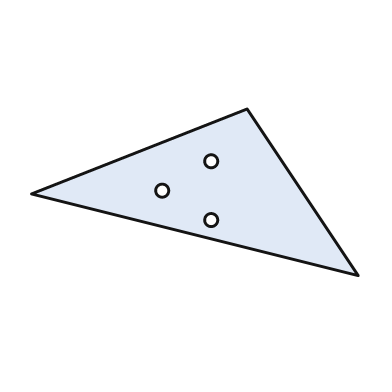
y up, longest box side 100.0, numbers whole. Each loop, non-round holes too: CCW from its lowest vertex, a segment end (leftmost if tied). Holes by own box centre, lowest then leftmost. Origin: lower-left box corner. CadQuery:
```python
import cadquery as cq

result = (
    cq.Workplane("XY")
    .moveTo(100.0, 0.0)
    .lineTo(66.0, 51.0)
    .lineTo(0.0, 25.0)
    .close()
    .moveTo(55.0, 17.0)
    .circle(2.0)
    .moveTo(40.0, 26.0)
    .circle(2.0)
    .moveTo(55.0, 35.0)
    .circle(2.0)
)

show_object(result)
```